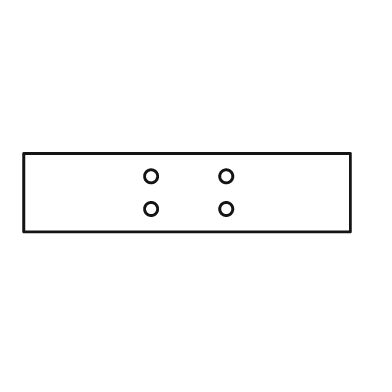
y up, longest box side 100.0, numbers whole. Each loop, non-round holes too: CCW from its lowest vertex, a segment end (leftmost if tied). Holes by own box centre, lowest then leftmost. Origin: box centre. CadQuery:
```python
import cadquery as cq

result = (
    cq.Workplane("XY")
    .moveTo(-50.0, -12.0)
    .lineTo(50.0, -12.0)
    .lineTo(50.0, 12.0)
    .lineTo(-50.0, 12.0)
    .close()
    .moveTo(-11.0, -5.0)
    .circle(2.0)
    .moveTo(12.0, -5.0)
    .circle(2.0)
    .moveTo(-11.0, 5.0)
    .circle(2.0)
    .moveTo(12.0, 5.0)
    .circle(2.0)
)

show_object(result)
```